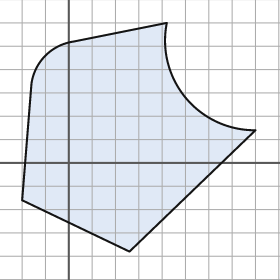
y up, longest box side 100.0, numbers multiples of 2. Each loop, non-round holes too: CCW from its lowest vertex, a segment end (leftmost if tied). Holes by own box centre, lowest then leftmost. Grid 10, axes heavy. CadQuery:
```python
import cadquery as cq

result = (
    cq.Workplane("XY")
    .moveTo(26.0, -38.0)
    .lineTo(80.0, 14.0)
    .threePointArc((50.0, 28.0), (42.0, 60.0))
    .lineTo(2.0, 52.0)
    .threePointArc((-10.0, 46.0), (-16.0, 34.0))
    .lineTo(-20.0, -16.0)
    .close()
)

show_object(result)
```